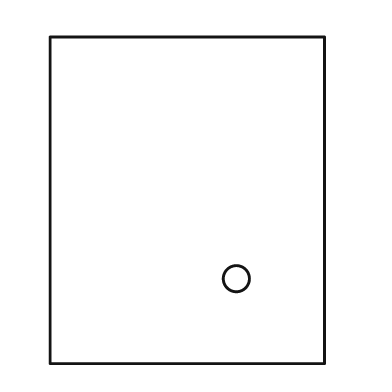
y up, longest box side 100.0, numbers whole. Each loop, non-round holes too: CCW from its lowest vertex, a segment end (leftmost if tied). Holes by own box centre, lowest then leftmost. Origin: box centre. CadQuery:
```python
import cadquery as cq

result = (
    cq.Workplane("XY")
    .moveTo(-42.0, -50.0)
    .lineTo(42.0, -50.0)
    .lineTo(42.0, 50.0)
    .lineTo(-42.0, 50.0)
    .close()
    .moveTo(15.0, -24.0)
    .circle(4.0)
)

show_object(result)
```